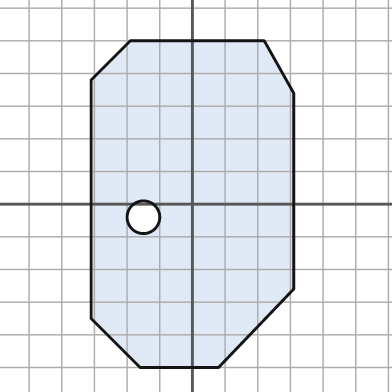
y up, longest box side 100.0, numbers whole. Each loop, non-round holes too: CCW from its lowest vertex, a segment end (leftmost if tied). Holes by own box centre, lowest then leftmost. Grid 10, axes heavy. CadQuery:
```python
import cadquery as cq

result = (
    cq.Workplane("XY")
    .moveTo(-16.0, -50.0)
    .lineTo(8.0, -50.0)
    .lineTo(31.0, -26.0)
    .lineTo(31.0, 34.0)
    .lineTo(22.0, 50.0)
    .lineTo(-19.0, 50.0)
    .lineTo(-31.0, 38.0)
    .lineTo(-31.0, -35.0)
    .close()
    .moveTo(-15.0, -4.0)
    .circle(5.0)
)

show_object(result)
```